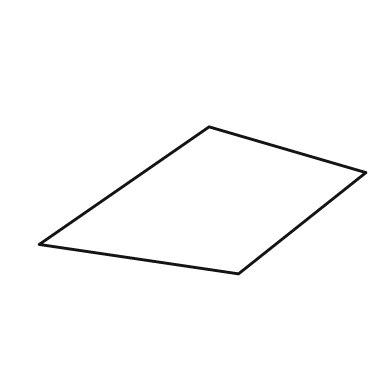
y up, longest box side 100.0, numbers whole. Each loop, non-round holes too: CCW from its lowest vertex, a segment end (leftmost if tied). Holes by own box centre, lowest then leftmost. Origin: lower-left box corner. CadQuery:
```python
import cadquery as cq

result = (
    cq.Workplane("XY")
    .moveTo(61.0, 0.0)
    .lineTo(100.0, 31.0)
    .lineTo(52.0, 45.0)
    .lineTo(0.0, 9.0)
    .close()
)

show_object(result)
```